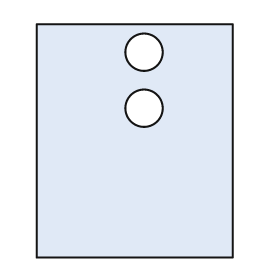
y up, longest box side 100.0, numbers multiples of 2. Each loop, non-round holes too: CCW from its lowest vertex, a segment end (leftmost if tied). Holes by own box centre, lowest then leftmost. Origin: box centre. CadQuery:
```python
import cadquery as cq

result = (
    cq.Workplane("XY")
    .moveTo(-42.0, -50.0)
    .lineTo(42.0, -50.0)
    .lineTo(42.0, 50.0)
    .lineTo(-42.0, 50.0)
    .close()
    .moveTo(4.0, 14.0)
    .circle(8.0)
    .moveTo(4.0, 38.0)
    .circle(8.0)
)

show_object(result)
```